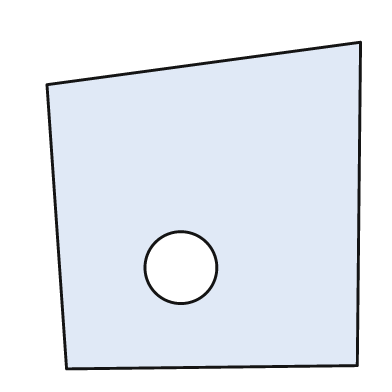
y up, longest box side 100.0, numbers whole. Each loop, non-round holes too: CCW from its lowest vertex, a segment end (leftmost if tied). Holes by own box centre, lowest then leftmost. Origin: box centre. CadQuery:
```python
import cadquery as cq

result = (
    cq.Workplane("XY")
    .moveTo(-42.0, -50.0)
    .lineTo(47.0, -49.0)
    .lineTo(48.0, 50.0)
    .lineTo(-48.0, 37.0)
    .close()
    .moveTo(-7.0, -19.0)
    .circle(11.0)
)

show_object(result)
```